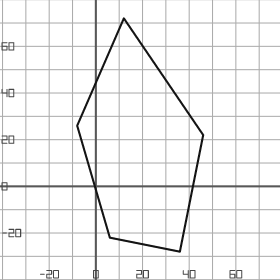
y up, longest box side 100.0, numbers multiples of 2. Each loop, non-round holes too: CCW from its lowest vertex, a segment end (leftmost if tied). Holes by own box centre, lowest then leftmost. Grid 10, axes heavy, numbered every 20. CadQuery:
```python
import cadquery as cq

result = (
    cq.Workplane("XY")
    .moveTo(36.0, -28.0)
    .lineTo(46.0, 22.0)
    .lineTo(12.0, 72.0)
    .lineTo(-8.0, 26.0)
    .lineTo(6.0, -22.0)
    .close()
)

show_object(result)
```